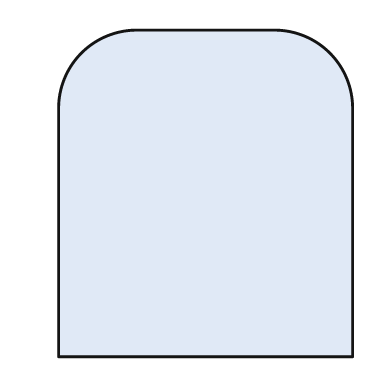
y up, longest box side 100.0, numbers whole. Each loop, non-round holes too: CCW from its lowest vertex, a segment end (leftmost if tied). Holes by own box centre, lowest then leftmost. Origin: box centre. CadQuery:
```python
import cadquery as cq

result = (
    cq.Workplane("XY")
    .moveTo(-45.0, -50.0)
    .lineTo(45.0, -50.0)
    .lineTo(45.0, 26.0)
    .threePointArc((38.0, 43.0), (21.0, 50.0))
    .lineTo(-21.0, 50.0)
    .threePointArc((-38.0, 43.0), (-45.0, 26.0))
    .close()
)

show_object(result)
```